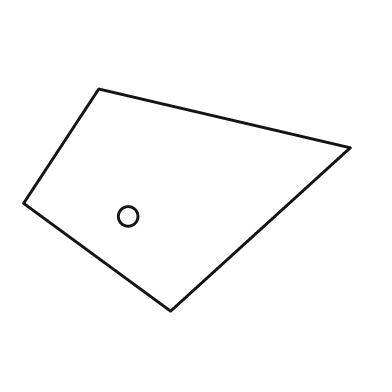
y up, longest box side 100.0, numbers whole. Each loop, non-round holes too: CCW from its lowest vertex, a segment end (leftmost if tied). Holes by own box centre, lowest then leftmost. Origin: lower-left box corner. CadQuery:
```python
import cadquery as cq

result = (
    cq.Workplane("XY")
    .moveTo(45.0, 0.0)
    .lineTo(100.0, 50.0)
    .lineTo(23.0, 68.0)
    .lineTo(0.0, 33.0)
    .close()
    .moveTo(32.0, 29.0)
    .circle(3.0)
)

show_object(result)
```